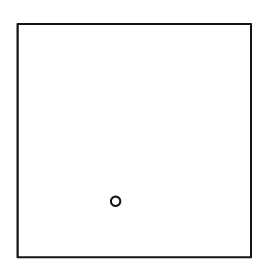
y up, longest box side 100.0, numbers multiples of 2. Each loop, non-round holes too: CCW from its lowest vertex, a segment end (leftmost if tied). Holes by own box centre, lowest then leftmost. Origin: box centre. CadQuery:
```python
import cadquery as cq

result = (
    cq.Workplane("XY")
    .moveTo(-50.0, -50.0)
    .lineTo(50.0, -50.0)
    .lineTo(50.0, 50.0)
    .lineTo(-50.0, 50.0)
    .close()
    .moveTo(-8.0, -26.0)
    .circle(2.0)
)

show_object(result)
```